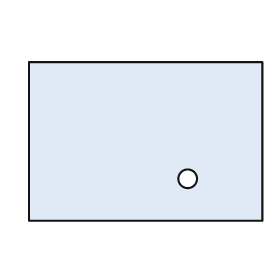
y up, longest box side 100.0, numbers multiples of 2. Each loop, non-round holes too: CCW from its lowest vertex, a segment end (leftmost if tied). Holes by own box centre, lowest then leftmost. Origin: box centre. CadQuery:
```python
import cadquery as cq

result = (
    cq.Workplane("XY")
    .moveTo(-50.0, -34.0)
    .lineTo(50.0, -34.0)
    .lineTo(50.0, 34.0)
    .lineTo(-50.0, 34.0)
    .close()
    .moveTo(18.0, -16.0)
    .circle(4.0)
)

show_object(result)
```